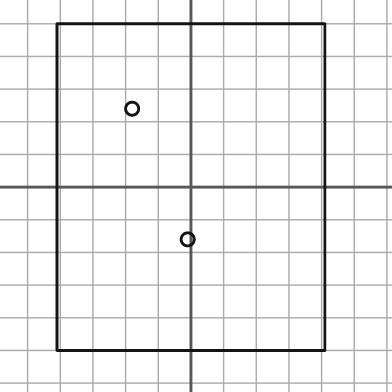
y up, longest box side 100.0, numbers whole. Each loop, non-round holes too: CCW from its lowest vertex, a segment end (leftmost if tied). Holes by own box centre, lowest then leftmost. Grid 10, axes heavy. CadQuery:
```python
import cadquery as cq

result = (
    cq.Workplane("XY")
    .moveTo(-41.0, -50.0)
    .lineTo(41.0, -50.0)
    .lineTo(41.0, 50.0)
    .lineTo(-41.0, 50.0)
    .close()
    .moveTo(-1.0, -16.0)
    .circle(2.0)
    .moveTo(-18.0, 24.0)
    .circle(2.0)
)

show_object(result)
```